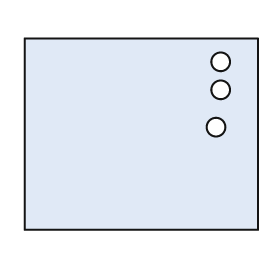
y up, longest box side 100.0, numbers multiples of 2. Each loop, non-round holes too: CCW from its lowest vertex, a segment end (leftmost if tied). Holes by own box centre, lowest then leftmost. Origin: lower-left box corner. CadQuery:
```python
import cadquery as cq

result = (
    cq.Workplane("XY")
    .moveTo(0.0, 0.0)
    .lineTo(100.0, 0.0)
    .lineTo(100.0, 82.0)
    .lineTo(0.0, 82.0)
    .close()
    .moveTo(82.0, 44.0)
    .circle(4.0)
    .moveTo(84.0, 60.0)
    .circle(4.0)
    .moveTo(84.0, 72.0)
    .circle(4.0)
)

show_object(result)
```